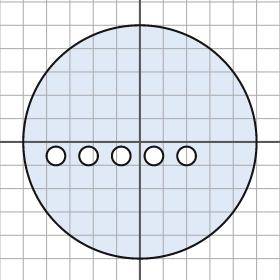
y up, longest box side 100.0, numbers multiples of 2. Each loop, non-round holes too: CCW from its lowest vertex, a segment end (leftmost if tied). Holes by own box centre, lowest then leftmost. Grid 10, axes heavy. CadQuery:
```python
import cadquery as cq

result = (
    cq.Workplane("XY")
    .moveTo(0.0, 0.0)
    .circle(50.0)
    .moveTo(-36.0, -6.0)
    .circle(4.0)
    .moveTo(-22.0, -6.0)
    .circle(4.0)
    .moveTo(-8.0, -6.0)
    .circle(4.0)
    .moveTo(6.0, -6.0)
    .circle(4.0)
    .moveTo(20.0, -6.0)
    .circle(4.0)
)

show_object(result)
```